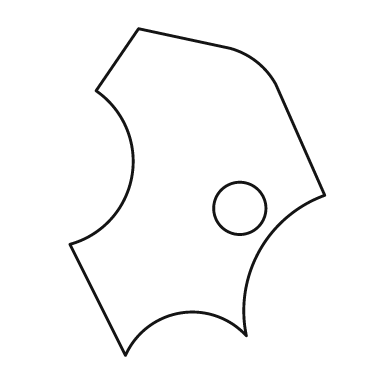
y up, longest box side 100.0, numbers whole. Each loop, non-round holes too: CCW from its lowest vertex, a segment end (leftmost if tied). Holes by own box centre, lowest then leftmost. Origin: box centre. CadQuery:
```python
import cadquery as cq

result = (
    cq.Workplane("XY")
    .moveTo(-22.0, -50.0)
    .threePointArc((-5.0, -37.0), (15.0, -44.0))
    .threePointArc((19.0, -18.0), (39.0, -1.0))
    .lineTo(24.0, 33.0)
    .threePointArc((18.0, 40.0), (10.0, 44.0))
    .lineTo(-18.0, 50.0)
    .lineTo(-31.0, 31.0)
    .threePointArc((-20.0, 5.0), (-39.0, -16.0))
    .close()
    .moveTo(13.0, -5.0)
    .circle(8.0)
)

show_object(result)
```